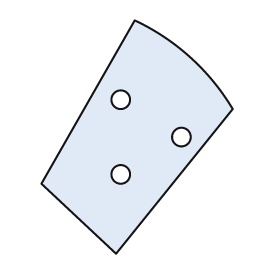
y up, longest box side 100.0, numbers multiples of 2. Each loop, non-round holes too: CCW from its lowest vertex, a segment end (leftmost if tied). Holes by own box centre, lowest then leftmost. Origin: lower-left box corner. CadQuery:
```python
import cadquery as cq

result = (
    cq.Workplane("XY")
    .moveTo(32.0, 0.0)
    .lineTo(82.0, 62.0)
    .threePointArc((64.0, 84.0), (40.0, 100.0))
    .lineTo(0.0, 30.0)
    .close()
    .moveTo(34.0, 34.0)
    .circle(4.0)
    .moveTo(60.0, 50.0)
    .circle(4.0)
    .moveTo(34.0, 66.0)
    .circle(4.0)
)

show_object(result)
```